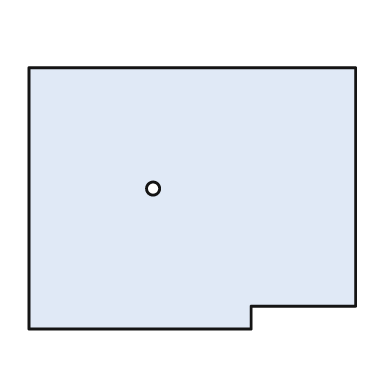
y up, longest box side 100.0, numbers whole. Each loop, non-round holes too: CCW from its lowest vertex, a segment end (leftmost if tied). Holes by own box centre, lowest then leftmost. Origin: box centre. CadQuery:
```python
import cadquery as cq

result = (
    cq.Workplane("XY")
    .moveTo(-50.0, -40.0)
    .lineTo(18.0, -40.0)
    .lineTo(18.0, -33.0)
    .lineTo(50.0, -33.0)
    .lineTo(50.0, 40.0)
    .lineTo(-50.0, 40.0)
    .close()
    .moveTo(-12.0, 3.0)
    .circle(2.0)
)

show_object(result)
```